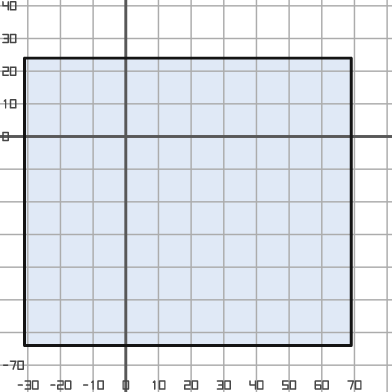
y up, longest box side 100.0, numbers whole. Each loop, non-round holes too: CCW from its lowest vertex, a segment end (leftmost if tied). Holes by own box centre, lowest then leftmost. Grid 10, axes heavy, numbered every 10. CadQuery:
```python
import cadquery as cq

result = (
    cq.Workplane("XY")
    .moveTo(-31.0, -64.0)
    .lineTo(69.0, -64.0)
    .lineTo(69.0, 24.0)
    .lineTo(-31.0, 24.0)
    .close()
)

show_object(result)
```